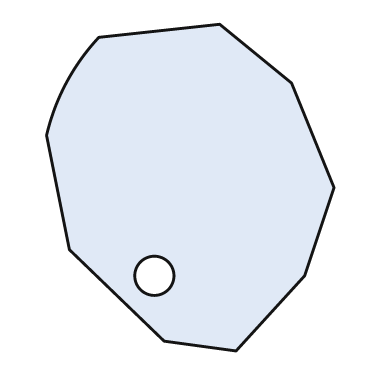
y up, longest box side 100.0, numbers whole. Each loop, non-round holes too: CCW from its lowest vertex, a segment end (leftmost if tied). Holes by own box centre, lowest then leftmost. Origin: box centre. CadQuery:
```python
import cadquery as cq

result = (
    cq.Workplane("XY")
    .moveTo(14.0, -50.0)
    .lineTo(35.0, -27.0)
    .lineTo(44.0, 0.0)
    .lineTo(31.0, 32.0)
    .lineTo(9.0, 50.0)
    .lineTo(-28.0, 46.0)
    .threePointArc((-38.0, 32.0), (-44.0, 16.0))
    .lineTo(-37.0, -19.0)
    .lineTo(-8.0, -47.0)
    .close()
    .moveTo(-11.0, -27.0)
    .circle(6.0)
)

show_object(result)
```